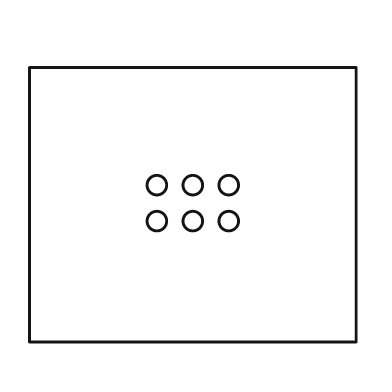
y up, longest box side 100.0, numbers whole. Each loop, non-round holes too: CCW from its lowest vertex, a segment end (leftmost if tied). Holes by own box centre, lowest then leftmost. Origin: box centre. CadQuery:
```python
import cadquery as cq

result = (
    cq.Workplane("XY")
    .moveTo(-50.0, -42.0)
    .lineTo(50.0, -42.0)
    .lineTo(50.0, 42.0)
    .lineTo(-50.0, 42.0)
    .close()
    .moveTo(-11.0, -5.0)
    .circle(3.0)
    .moveTo(0.0, -5.0)
    .circle(3.0)
    .moveTo(11.0, -5.0)
    .circle(3.0)
    .moveTo(-11.0, 6.0)
    .circle(3.0)
    .moveTo(0.0, 6.0)
    .circle(3.0)
    .moveTo(11.0, 6.0)
    .circle(3.0)
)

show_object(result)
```